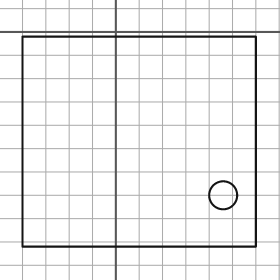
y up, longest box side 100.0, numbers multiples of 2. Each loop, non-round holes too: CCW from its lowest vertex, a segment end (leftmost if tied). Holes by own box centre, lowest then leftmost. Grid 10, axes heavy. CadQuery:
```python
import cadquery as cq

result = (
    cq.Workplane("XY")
    .moveTo(-40.0, -92.0)
    .lineTo(60.0, -92.0)
    .lineTo(60.0, -2.0)
    .lineTo(-40.0, -2.0)
    .close()
    .moveTo(46.0, -70.0)
    .circle(6.0)
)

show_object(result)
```